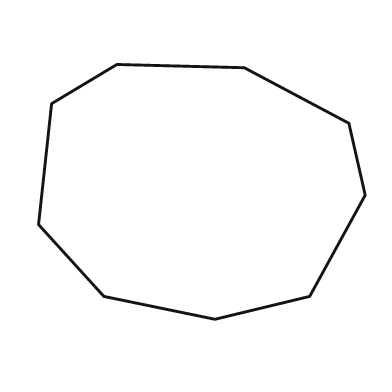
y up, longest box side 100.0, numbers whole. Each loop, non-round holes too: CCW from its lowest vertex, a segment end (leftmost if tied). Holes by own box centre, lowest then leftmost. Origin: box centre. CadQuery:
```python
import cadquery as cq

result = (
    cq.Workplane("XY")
    .moveTo(4.0, -39.0)
    .lineTo(33.0, -32.0)
    .lineTo(50.0, -1.0)
    .lineTo(45.0, 21.0)
    .lineTo(13.0, 38.0)
    .lineTo(-26.0, 39.0)
    .lineTo(-46.0, 27.0)
    .lineTo(-50.0, -10.0)
    .lineTo(-30.0, -32.0)
    .close()
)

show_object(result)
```